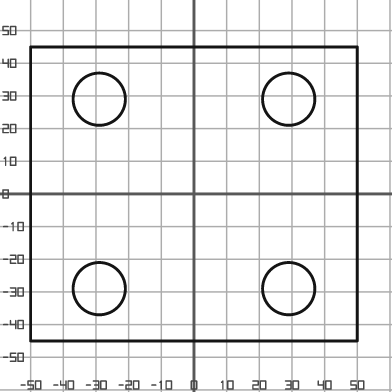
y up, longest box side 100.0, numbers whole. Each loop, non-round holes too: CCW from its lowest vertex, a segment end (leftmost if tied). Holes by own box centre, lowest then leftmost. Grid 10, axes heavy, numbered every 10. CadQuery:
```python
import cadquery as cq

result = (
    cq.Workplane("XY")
    .moveTo(-50.0, -45.0)
    .lineTo(50.0, -45.0)
    .lineTo(50.0, 45.0)
    .lineTo(-50.0, 45.0)
    .close()
    .moveTo(-29.0, -29.0)
    .circle(8.0)
    .moveTo(29.0, -29.0)
    .circle(8.0)
    .moveTo(-29.0, 29.0)
    .circle(8.0)
    .moveTo(29.0, 29.0)
    .circle(8.0)
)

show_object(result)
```